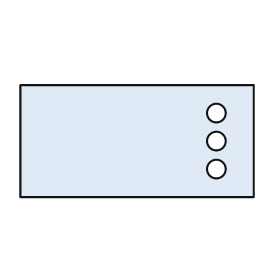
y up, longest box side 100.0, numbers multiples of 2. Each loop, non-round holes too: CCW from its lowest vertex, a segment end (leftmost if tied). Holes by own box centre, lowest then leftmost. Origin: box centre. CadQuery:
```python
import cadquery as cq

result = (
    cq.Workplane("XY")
    .moveTo(-50.0, -24.0)
    .lineTo(50.0, -24.0)
    .lineTo(50.0, 24.0)
    .lineTo(-50.0, 24.0)
    .close()
    .moveTo(34.0, -12.0)
    .circle(4.0)
    .moveTo(34.0, 0.0)
    .circle(4.0)
    .moveTo(34.0, 12.0)
    .circle(4.0)
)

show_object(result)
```